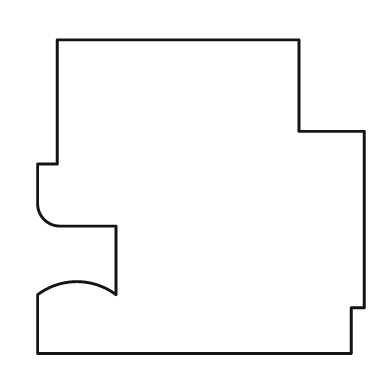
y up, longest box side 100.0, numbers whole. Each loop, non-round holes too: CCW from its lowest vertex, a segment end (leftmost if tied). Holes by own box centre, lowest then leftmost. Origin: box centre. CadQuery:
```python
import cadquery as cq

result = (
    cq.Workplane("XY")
    .moveTo(-50.0, -48.0)
    .lineTo(46.0, -48.0)
    .lineTo(46.0, -34.0)
    .lineTo(50.0, -34.0)
    .lineTo(50.0, 20.0)
    .lineTo(30.0, 20.0)
    .lineTo(30.0, 48.0)
    .lineTo(-44.0, 48.0)
    .lineTo(-44.0, 10.0)
    .lineTo(-50.0, 10.0)
    .lineTo(-50.0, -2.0)
    .threePointArc((-48.0, -7.0), (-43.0, -9.0))
    .lineTo(-26.0, -9.0)
    .lineTo(-26.0, -30.0)
    .threePointArc((-38.0, -26.0), (-50.0, -30.0))
    .close()
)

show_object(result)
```